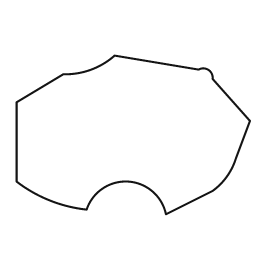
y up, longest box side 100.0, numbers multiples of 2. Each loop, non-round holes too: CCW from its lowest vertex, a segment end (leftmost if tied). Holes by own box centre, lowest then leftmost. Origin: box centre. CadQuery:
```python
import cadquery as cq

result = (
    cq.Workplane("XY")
    .moveTo(14.0, -34.0)
    .lineTo(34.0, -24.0)
    .threePointArc((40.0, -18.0), (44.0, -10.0))
    .lineTo(50.0, 6.0)
    .lineTo(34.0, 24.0)
    .threePointArc((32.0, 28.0), (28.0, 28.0))
    .lineTo(-8.0, 34.0)
    .threePointArc((-18.0, 28.0), (-30.0, 26.0))
    .lineTo(-50.0, 14.0)
    .lineTo(-50.0, -20.0)
    .threePointArc((-36.0, -28.0), (-20.0, -32.0))
    .threePointArc((-2.0, -20.0), (14.0, -34.0))
    .close()
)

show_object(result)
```